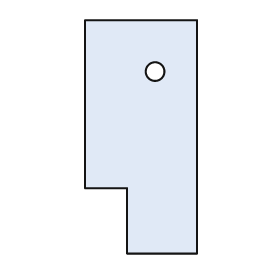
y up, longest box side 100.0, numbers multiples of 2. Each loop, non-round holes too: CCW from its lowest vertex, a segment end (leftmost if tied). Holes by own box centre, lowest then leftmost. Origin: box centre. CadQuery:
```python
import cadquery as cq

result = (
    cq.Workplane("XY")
    .moveTo(-6.0, -50.0)
    .lineTo(24.0, -50.0)
    .lineTo(24.0, 50.0)
    .lineTo(-24.0, 50.0)
    .lineTo(-24.0, -22.0)
    .lineTo(-6.0, -22.0)
    .close()
    .moveTo(6.0, 28.0)
    .circle(4.0)
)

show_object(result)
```